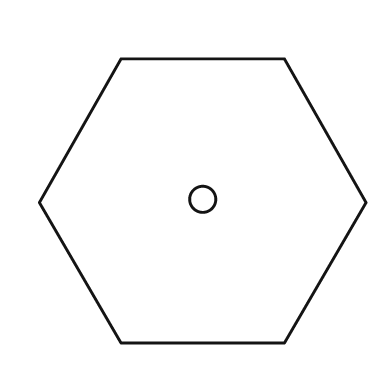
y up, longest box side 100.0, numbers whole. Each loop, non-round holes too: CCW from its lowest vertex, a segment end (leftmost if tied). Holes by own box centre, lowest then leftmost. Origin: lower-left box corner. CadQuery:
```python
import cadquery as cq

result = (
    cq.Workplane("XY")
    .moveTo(25.0, 0.0)
    .lineTo(75.0, 0.0)
    .lineTo(100.0, 43.0)
    .lineTo(75.0, 87.0)
    .lineTo(25.0, 87.0)
    .lineTo(0.0, 43.0)
    .close()
    .moveTo(50.0, 44.0)
    .circle(4.0)
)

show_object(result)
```